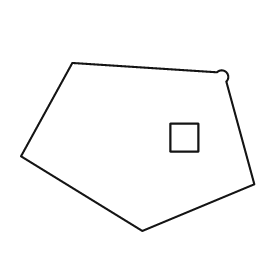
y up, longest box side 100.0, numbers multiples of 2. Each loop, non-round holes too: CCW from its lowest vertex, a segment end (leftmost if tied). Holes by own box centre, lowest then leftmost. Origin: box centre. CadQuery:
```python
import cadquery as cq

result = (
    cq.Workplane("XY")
    .moveTo(2.0, -36.0)
    .lineTo(50.0, -16.0)
    .lineTo(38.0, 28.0)
    .threePointArc((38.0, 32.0), (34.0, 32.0))
    .lineTo(-28.0, 36.0)
    .lineTo(-50.0, -4.0)
    .close()
    .moveTo(14.0, -2.0)
    .lineTo(26.0, -2.0)
    .lineTo(26.0, 10.0)
    .lineTo(14.0, 10.0)
    .close()
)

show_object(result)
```